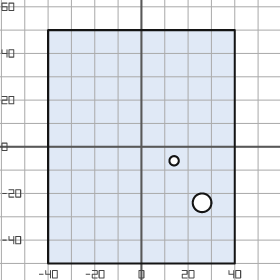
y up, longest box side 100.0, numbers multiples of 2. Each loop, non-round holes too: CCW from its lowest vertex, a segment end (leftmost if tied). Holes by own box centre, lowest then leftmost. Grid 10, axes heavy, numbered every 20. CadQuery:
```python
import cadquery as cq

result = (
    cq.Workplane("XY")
    .moveTo(-40.0, -50.0)
    .lineTo(40.0, -50.0)
    .lineTo(40.0, 50.0)
    .lineTo(-40.0, 50.0)
    .close()
    .moveTo(26.0, -24.0)
    .circle(4.0)
    .moveTo(14.0, -6.0)
    .circle(2.0)
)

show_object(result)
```